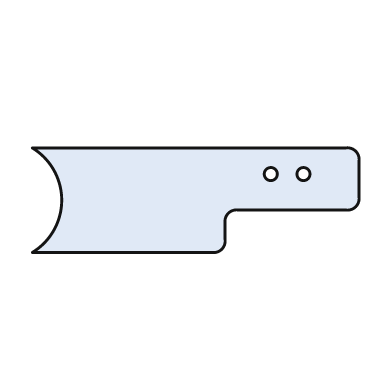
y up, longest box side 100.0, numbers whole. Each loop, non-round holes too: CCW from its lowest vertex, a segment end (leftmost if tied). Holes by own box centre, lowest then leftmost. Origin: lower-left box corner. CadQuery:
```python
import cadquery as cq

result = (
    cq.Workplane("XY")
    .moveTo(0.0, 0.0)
    .lineTo(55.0, 0.0)
    .threePointArc((58.0, 1.0), (59.0, 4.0))
    .lineTo(59.0, 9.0)
    .threePointArc((60.0, 12.0), (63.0, 13.0))
    .lineTo(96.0, 13.0)
    .threePointArc((99.0, 14.0), (100.0, 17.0))
    .lineTo(100.0, 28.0)
    .threePointArc((99.0, 31.0), (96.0, 32.0))
    .lineTo(0.0, 32.0)
    .threePointArc((9.0, 16.0), (0.0, 0.0))
    .close()
    .moveTo(73.0, 24.0)
    .circle(2.0)
    .moveTo(83.0, 24.0)
    .circle(2.0)
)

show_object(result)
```